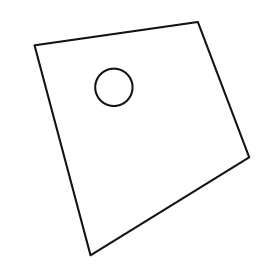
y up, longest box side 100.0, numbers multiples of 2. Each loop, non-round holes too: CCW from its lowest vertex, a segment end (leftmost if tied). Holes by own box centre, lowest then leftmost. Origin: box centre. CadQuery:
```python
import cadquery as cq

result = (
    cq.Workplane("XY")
    .moveTo(-22.0, -50.0)
    .lineTo(46.0, -8.0)
    .lineTo(24.0, 50.0)
    .lineTo(-46.0, 40.0)
    .close()
    .moveTo(-12.0, 22.0)
    .circle(8.0)
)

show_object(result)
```